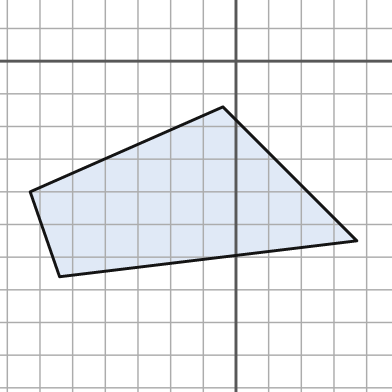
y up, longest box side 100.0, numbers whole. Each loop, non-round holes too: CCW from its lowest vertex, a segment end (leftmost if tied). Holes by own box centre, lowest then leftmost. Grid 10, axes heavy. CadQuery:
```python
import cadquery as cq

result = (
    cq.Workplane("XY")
    .moveTo(-54.0, -66.0)
    .lineTo(37.0, -55.0)
    .lineTo(-4.0, -14.0)
    .lineTo(-63.0, -40.0)
    .close()
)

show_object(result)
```